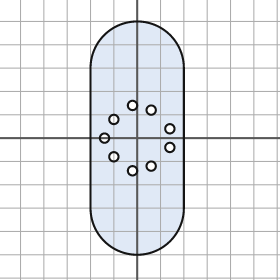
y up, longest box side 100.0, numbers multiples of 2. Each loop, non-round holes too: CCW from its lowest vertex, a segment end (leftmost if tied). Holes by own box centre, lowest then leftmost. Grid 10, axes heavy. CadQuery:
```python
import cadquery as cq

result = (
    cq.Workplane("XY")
    .moveTo(-20.0, -30.0)
    .threePointArc((0.0, -50.0), (20.0, -30.0))
    .lineTo(20.0, 30.0)
    .threePointArc((0.0, 50.0), (-20.0, 30.0))
    .close()
    .moveTo(-2.0, -14.0)
    .circle(2.0)
    .moveTo(6.0, -12.0)
    .circle(2.0)
    .moveTo(-10.0, -8.0)
    .circle(2.0)
    .moveTo(14.0, -4.0)
    .circle(2.0)
    .moveTo(-14.0, 0.0)
    .circle(2.0)
    .moveTo(14.0, 4.0)
    .circle(2.0)
    .moveTo(-10.0, 8.0)
    .circle(2.0)
    .moveTo(6.0, 12.0)
    .circle(2.0)
    .moveTo(-2.0, 14.0)
    .circle(2.0)
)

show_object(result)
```